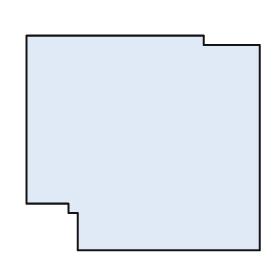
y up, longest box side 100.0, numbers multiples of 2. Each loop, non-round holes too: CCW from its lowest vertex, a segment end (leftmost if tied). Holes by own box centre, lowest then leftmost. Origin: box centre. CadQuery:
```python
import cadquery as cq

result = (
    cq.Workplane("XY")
    .moveTo(-28.0, -46.0)
    .lineTo(50.0, -46.0)
    .lineTo(50.0, 42.0)
    .lineTo(26.0, 42.0)
    .lineTo(26.0, 46.0)
    .lineTo(-50.0, 46.0)
    .lineTo(-50.0, -26.0)
    .lineTo(-32.0, -26.0)
    .lineTo(-32.0, -30.0)
    .lineTo(-28.0, -30.0)
    .close()
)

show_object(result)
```